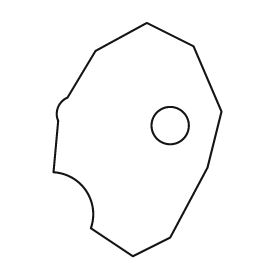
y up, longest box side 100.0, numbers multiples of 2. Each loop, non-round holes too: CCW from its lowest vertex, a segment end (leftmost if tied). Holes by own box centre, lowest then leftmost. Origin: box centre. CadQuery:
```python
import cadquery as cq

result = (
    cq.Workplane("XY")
    .moveTo(-2.0, -50.0)
    .lineTo(14.0, -42.0)
    .lineTo(30.0, -12.0)
    .lineTo(36.0, 12.0)
    .lineTo(24.0, 40.0)
    .lineTo(4.0, 50.0)
    .lineTo(-18.0, 38.0)
    .lineTo(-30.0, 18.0)
    .threePointArc((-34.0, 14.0), (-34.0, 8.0))
    .lineTo(-36.0, -14.0)
    .threePointArc((-22.0, -22.0), (-20.0, -38.0))
    .close()
    .moveTo(14.0, 6.0)
    .circle(8.0)
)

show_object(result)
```